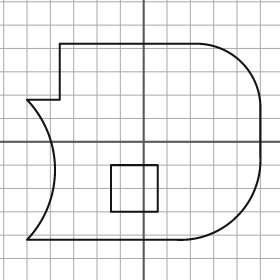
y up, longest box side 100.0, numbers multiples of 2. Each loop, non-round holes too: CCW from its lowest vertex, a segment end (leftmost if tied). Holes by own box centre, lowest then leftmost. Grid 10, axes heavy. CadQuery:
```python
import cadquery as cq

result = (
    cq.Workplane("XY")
    .moveTo(-50.0, -42.0)
    .lineTo(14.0, -42.0)
    .threePointArc((40.0, -32.0), (50.0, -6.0))
    .lineTo(50.0, 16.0)
    .threePointArc((42.0, 34.0), (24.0, 42.0))
    .lineTo(-36.0, 42.0)
    .lineTo(-36.0, 18.0)
    .lineTo(-50.0, 18.0)
    .threePointArc((-38.0, -12.0), (-50.0, -42.0))
    .close()
    .moveTo(-14.0, -30.0)
    .lineTo(6.0, -30.0)
    .lineTo(6.0, -10.0)
    .lineTo(-14.0, -10.0)
    .close()
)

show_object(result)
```